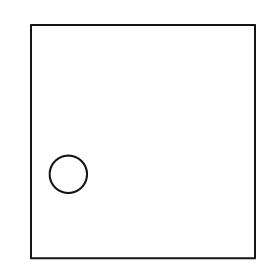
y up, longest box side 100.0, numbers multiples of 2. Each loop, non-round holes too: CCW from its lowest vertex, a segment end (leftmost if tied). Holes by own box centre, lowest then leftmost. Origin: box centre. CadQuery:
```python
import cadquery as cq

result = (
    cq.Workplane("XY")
    .moveTo(-48.0, -50.0)
    .lineTo(48.0, -50.0)
    .lineTo(48.0, 50.0)
    .lineTo(-48.0, 50.0)
    .close()
    .moveTo(-32.0, -14.0)
    .circle(8.0)
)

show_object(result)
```